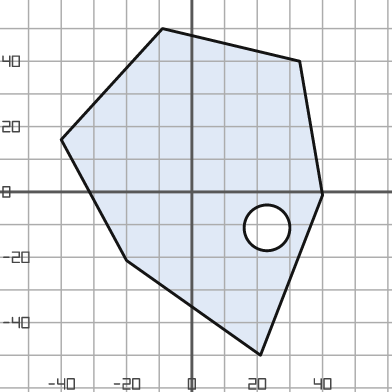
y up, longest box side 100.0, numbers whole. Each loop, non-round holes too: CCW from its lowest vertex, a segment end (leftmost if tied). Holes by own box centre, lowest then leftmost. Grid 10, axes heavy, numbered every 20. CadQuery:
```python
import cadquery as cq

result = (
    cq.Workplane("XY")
    .moveTo(21.0, -50.0)
    .lineTo(40.0, -1.0)
    .lineTo(33.0, 40.0)
    .lineTo(-9.0, 50.0)
    .lineTo(-40.0, 16.0)
    .lineTo(-20.0, -21.0)
    .close()
    .moveTo(23.0, -11.0)
    .circle(7.0)
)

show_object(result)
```